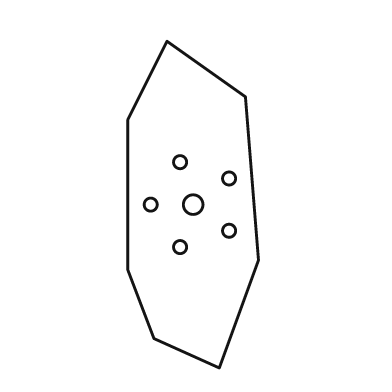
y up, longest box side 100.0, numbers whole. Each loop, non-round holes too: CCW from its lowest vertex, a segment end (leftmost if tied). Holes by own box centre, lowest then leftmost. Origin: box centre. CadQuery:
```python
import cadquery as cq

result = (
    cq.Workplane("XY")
    .moveTo(8.0, -50.0)
    .lineTo(20.0, -17.0)
    .lineTo(16.0, 33.0)
    .lineTo(-8.0, 50.0)
    .lineTo(-20.0, 26.0)
    .lineTo(-20.0, -20.0)
    .lineTo(-12.0, -41.0)
    .close()
    .moveTo(-4.0, -13.0)
    .circle(2.0)
    .moveTo(11.0, -8.0)
    .circle(2.0)
    .moveTo(-13.0, 0.0)
    .circle(2.0)
    .moveTo(0.0, 0.0)
    .circle(3.0)
    .moveTo(11.0, 8.0)
    .circle(2.0)
    .moveTo(-4.0, 13.0)
    .circle(2.0)
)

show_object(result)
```